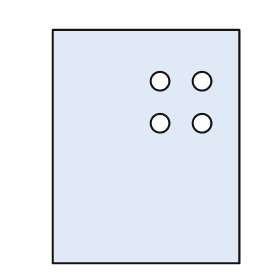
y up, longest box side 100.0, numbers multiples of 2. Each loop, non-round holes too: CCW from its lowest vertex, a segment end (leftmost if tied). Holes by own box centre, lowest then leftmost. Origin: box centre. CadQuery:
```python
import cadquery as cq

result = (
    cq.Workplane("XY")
    .moveTo(-40.0, -50.0)
    .lineTo(40.0, -50.0)
    .lineTo(40.0, 50.0)
    .lineTo(-40.0, 50.0)
    .close()
    .moveTo(6.0, 10.0)
    .circle(4.0)
    .moveTo(24.0, 10.0)
    .circle(4.0)
    .moveTo(6.0, 28.0)
    .circle(4.0)
    .moveTo(24.0, 28.0)
    .circle(4.0)
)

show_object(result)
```